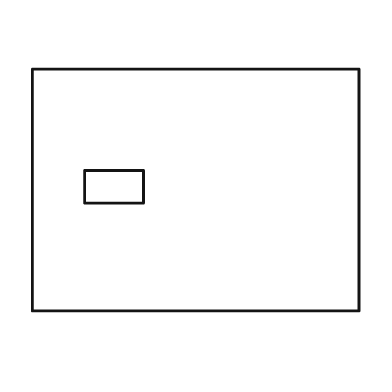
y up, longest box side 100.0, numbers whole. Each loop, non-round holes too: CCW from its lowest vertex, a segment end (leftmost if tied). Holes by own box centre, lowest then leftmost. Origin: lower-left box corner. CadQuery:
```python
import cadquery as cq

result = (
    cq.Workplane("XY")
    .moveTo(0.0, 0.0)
    .lineTo(100.0, 0.0)
    .lineTo(100.0, 74.0)
    .lineTo(0.0, 74.0)
    .close()
    .moveTo(16.0, 33.0)
    .lineTo(34.0, 33.0)
    .lineTo(34.0, 43.0)
    .lineTo(16.0, 43.0)
    .close()
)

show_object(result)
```